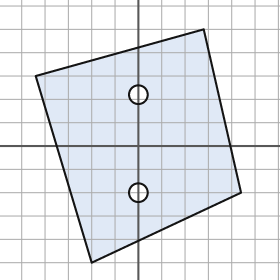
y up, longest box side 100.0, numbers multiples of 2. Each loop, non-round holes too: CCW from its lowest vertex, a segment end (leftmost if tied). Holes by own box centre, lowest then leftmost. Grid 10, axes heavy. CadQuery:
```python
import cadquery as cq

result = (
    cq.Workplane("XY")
    .moveTo(-20.0, -50.0)
    .lineTo(44.0, -20.0)
    .lineTo(28.0, 50.0)
    .lineTo(-44.0, 30.0)
    .close()
    .moveTo(0.0, -20.0)
    .circle(4.0)
    .moveTo(0.0, 22.0)
    .circle(4.0)
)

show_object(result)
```